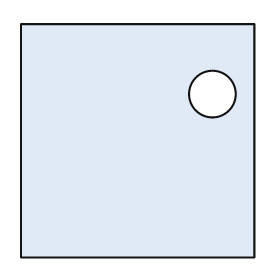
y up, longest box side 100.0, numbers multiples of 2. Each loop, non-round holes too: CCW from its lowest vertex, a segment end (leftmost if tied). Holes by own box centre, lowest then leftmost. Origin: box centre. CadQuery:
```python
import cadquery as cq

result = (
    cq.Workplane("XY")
    .moveTo(-50.0, -50.0)
    .lineTo(50.0, -50.0)
    .lineTo(50.0, 50.0)
    .lineTo(-50.0, 50.0)
    .close()
    .moveTo(32.0, 20.0)
    .circle(10.0)
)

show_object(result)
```